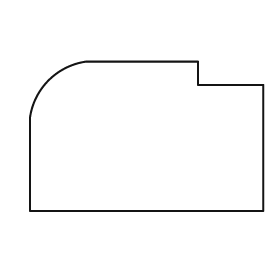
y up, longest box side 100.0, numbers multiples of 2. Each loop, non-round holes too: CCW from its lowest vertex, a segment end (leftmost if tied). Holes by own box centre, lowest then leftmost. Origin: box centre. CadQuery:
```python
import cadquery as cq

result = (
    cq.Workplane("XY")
    .moveTo(-50.0, -32.0)
    .lineTo(50.0, -32.0)
    .lineTo(50.0, 22.0)
    .lineTo(22.0, 22.0)
    .lineTo(22.0, 32.0)
    .lineTo(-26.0, 32.0)
    .threePointArc((-42.0, 24.0), (-50.0, 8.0))
    .close()
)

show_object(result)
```